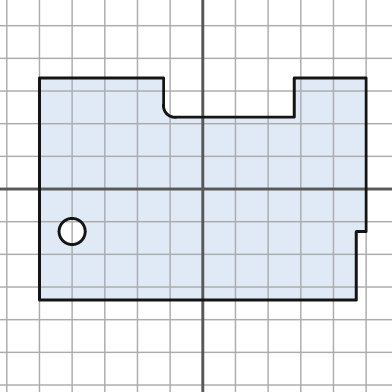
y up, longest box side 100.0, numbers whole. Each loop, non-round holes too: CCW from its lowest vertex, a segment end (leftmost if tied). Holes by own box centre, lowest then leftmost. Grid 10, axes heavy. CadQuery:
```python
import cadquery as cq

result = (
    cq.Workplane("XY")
    .moveTo(-50.0, -34.0)
    .lineTo(47.0, -34.0)
    .lineTo(47.0, -13.0)
    .lineTo(50.0, -13.0)
    .lineTo(50.0, 34.0)
    .lineTo(28.0, 34.0)
    .lineTo(28.0, 22.0)
    .lineTo(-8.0, 22.0)
    .threePointArc((-11.0, 23.0), (-12.0, 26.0))
    .lineTo(-12.0, 34.0)
    .lineTo(-50.0, 34.0)
    .close()
    .moveTo(-40.0, -13.0)
    .circle(4.0)
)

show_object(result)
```